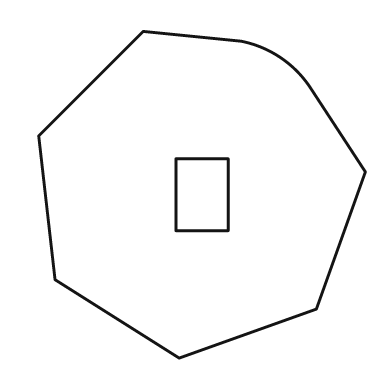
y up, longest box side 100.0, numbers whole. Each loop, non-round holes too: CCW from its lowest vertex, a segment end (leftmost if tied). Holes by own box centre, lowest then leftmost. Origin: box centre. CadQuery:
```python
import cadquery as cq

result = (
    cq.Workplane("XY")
    .moveTo(-7.0, -50.0)
    .lineTo(35.0, -35.0)
    .lineTo(50.0, 7.0)
    .lineTo(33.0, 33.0)
    .threePointArc((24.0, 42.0), (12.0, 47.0))
    .lineTo(-18.0, 50.0)
    .lineTo(-50.0, 18.0)
    .lineTo(-45.0, -26.0)
    .close()
    .moveTo(-8.0, -11.0)
    .lineTo(8.0, -11.0)
    .lineTo(8.0, 11.0)
    .lineTo(-8.0, 11.0)
    .close()
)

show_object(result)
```